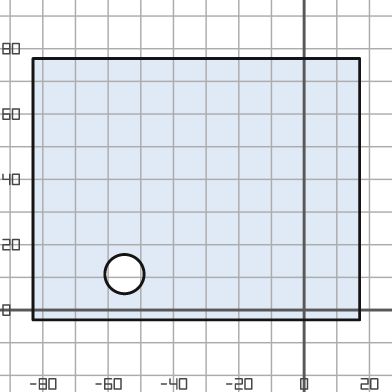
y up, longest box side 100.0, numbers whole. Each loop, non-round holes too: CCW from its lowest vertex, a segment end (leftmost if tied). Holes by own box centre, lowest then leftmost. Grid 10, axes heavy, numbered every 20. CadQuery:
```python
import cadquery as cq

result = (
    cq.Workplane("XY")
    .moveTo(-83.0, -3.0)
    .lineTo(17.0, -3.0)
    .lineTo(17.0, 77.0)
    .lineTo(-83.0, 77.0)
    .close()
    .moveTo(-55.0, 11.0)
    .circle(6.0)
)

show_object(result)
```